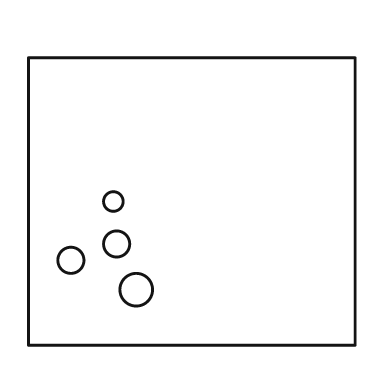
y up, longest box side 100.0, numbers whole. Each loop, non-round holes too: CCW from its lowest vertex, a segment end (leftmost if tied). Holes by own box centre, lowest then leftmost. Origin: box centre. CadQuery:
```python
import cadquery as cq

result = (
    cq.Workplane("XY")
    .moveTo(-50.0, -44.0)
    .lineTo(50.0, -44.0)
    .lineTo(50.0, 44.0)
    .lineTo(-50.0, 44.0)
    .close()
    .moveTo(-17.0, -27.0)
    .circle(5.0)
    .moveTo(-37.0, -18.0)
    .circle(4.0)
    .moveTo(-23.0, -13.0)
    .circle(4.0)
    .moveTo(-24.0, 0.0)
    .circle(3.0)
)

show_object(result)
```